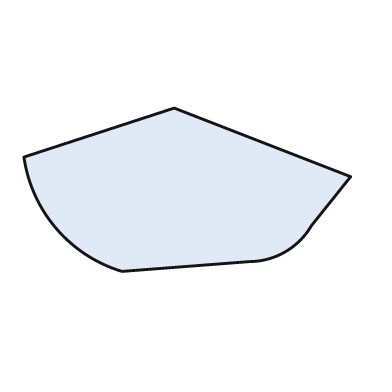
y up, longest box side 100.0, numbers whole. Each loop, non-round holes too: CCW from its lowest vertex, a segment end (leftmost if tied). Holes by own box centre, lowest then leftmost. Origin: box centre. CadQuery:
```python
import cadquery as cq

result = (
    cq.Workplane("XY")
    .moveTo(-20.0, -25.0)
    .lineTo(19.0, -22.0)
    .threePointArc((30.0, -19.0), (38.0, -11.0))
    .lineTo(50.0, 4.0)
    .lineTo(-4.0, 25.0)
    .lineTo(-50.0, 10.0)
    .threePointArc((-40.0, -12.0), (-20.0, -25.0))
    .close()
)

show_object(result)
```